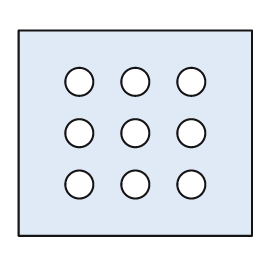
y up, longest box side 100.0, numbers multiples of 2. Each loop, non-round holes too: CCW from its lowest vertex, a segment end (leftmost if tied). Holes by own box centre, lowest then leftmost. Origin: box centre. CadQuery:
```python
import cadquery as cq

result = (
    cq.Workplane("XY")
    .moveTo(-50.0, -44.0)
    .lineTo(50.0, -44.0)
    .lineTo(50.0, 44.0)
    .lineTo(-50.0, 44.0)
    .close()
    .moveTo(-24.0, -22.0)
    .circle(6.0)
    .moveTo(0.0, -22.0)
    .circle(6.0)
    .moveTo(24.0, -22.0)
    .circle(6.0)
    .moveTo(-24.0, 0.0)
    .circle(6.0)
    .moveTo(0.0, 0.0)
    .circle(6.0)
    .moveTo(24.0, 0.0)
    .circle(6.0)
    .moveTo(-24.0, 22.0)
    .circle(6.0)
    .moveTo(0.0, 22.0)
    .circle(6.0)
    .moveTo(24.0, 22.0)
    .circle(6.0)
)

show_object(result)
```